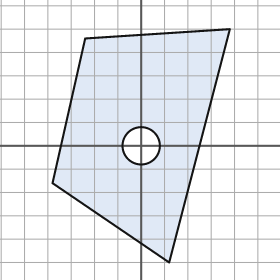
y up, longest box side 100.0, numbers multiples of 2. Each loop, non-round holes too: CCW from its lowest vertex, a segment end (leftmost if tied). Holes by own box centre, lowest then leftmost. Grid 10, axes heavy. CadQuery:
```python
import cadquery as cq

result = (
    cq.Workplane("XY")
    .moveTo(12.0, -50.0)
    .lineTo(38.0, 50.0)
    .lineTo(-24.0, 46.0)
    .lineTo(-38.0, -16.0)
    .close()
    .moveTo(0.0, 0.0)
    .circle(8.0)
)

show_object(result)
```